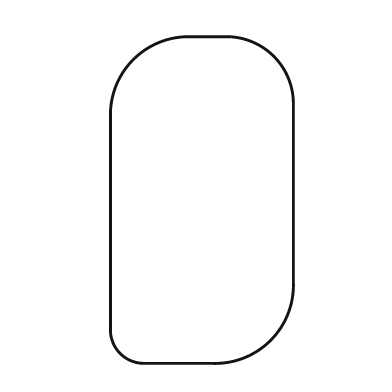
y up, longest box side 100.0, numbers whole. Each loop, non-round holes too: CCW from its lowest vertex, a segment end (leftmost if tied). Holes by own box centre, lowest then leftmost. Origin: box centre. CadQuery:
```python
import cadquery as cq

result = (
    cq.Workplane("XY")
    .moveTo(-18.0, -50.0)
    .lineTo(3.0, -50.0)
    .threePointArc((21.0, -43.0), (28.0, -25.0))
    .lineTo(28.0, 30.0)
    .threePointArc((22.0, 44.0), (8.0, 50.0))
    .lineTo(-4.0, 50.0)
    .threePointArc((-21.0, 43.0), (-28.0, 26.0))
    .lineTo(-28.0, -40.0)
    .threePointArc((-25.0, -47.0), (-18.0, -50.0))
    .close()
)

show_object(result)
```